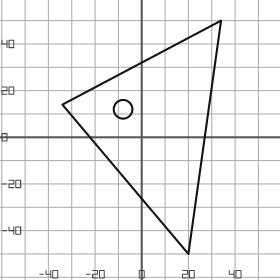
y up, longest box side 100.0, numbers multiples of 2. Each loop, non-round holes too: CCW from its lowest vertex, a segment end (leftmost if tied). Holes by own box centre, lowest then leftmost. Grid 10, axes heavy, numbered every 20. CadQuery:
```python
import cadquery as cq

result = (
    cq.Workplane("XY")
    .moveTo(20.0, -50.0)
    .lineTo(34.0, 50.0)
    .lineTo(-34.0, 14.0)
    .close()
    .moveTo(-8.0, 12.0)
    .circle(4.0)
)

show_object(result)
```